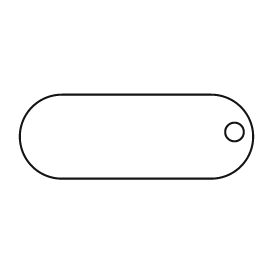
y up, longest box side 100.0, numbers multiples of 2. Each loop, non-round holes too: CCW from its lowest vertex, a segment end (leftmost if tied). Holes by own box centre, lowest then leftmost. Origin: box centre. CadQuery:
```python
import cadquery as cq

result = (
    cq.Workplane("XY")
    .moveTo(-32.0, -18.0)
    .lineTo(32.0, -18.0)
    .threePointArc((50.0, 0.0), (32.0, 18.0))
    .lineTo(-32.0, 18.0)
    .threePointArc((-50.0, 0.0), (-32.0, -18.0))
    .close()
    .moveTo(42.0, 2.0)
    .circle(4.0)
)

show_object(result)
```